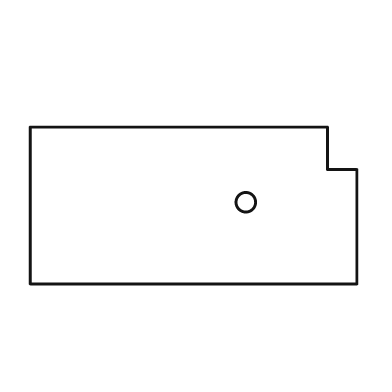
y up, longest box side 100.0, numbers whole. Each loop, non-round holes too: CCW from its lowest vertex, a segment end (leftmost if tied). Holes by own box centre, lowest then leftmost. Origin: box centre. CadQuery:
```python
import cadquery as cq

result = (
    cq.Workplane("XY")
    .moveTo(-50.0, -24.0)
    .lineTo(50.0, -24.0)
    .lineTo(50.0, 11.0)
    .lineTo(41.0, 11.0)
    .lineTo(41.0, 24.0)
    .lineTo(-50.0, 24.0)
    .close()
    .moveTo(16.0, 1.0)
    .circle(3.0)
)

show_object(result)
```